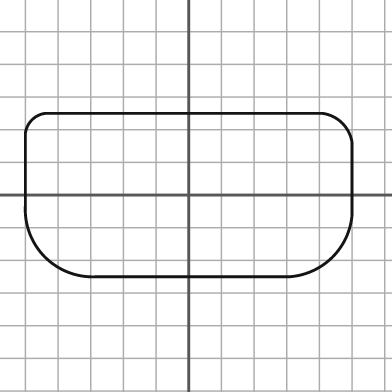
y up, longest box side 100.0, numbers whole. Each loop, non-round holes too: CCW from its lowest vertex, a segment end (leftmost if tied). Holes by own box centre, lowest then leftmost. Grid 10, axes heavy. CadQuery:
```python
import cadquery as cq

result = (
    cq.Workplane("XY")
    .moveTo(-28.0, -25.0)
    .lineTo(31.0, -25.0)
    .threePointArc((44.0, -19.0), (50.0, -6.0))
    .lineTo(50.0, 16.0)
    .threePointArc((47.0, 22.0), (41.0, 25.0))
    .lineTo(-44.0, 25.0)
    .threePointArc((-48.0, 23.0), (-50.0, 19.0))
    .lineTo(-50.0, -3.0)
    .threePointArc((-44.0, -19.0), (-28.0, -25.0))
    .close()
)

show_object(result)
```